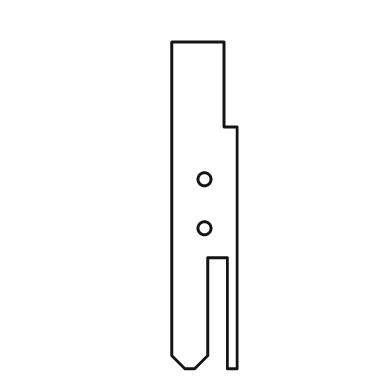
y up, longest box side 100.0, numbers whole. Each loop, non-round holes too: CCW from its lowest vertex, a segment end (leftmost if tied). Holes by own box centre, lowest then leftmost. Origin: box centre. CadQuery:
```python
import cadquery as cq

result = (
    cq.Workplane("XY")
    .moveTo(-6.0, -50.0)
    .lineTo(-3.0, -50.0)
    .lineTo(1.0, -46.0)
    .lineTo(1.0, -16.0)
    .lineTo(7.0, -16.0)
    .lineTo(7.0, -50.0)
    .lineTo(10.0, -50.0)
    .lineTo(10.0, 24.0)
    .lineTo(6.0, 24.0)
    .lineTo(6.0, 50.0)
    .lineTo(-10.0, 50.0)
    .lineTo(-10.0, -46.0)
    .close()
    .moveTo(0.0, -7.0)
    .circle(2.0)
    .moveTo(0.0, 8.0)
    .circle(2.0)
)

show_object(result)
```